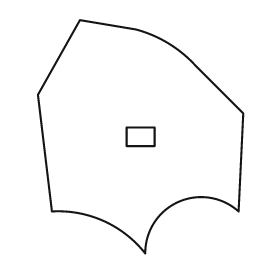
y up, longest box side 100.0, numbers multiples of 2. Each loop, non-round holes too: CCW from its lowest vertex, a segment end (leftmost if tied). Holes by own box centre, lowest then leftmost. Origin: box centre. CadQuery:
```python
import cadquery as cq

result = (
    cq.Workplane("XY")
    .moveTo(2.0, -50.0)
    .threePointArc((16.0, -28.0), (42.0, -32.0))
    .lineTo(44.0, 10.0)
    .lineTo(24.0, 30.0)
    .threePointArc((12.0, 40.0), (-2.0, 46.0))
    .lineTo(-26.0, 50.0)
    .lineTo(-44.0, 18.0)
    .lineTo(-38.0, -32.0)
    .threePointArc((-16.0, -36.0), (2.0, -50.0))
    .close()
    .moveTo(-6.0, -4.0)
    .lineTo(6.0, -4.0)
    .lineTo(6.0, 4.0)
    .lineTo(-6.0, 4.0)
    .close()
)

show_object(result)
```